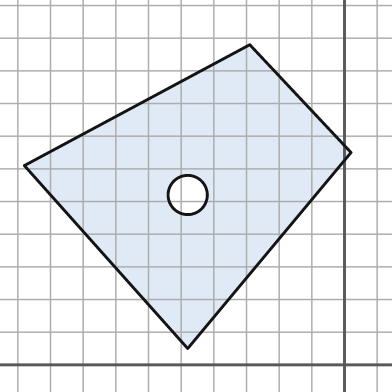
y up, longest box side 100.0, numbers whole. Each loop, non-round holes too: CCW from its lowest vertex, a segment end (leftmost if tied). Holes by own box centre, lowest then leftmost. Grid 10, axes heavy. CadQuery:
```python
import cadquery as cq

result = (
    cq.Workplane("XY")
    .moveTo(-48.0, 5.0)
    .lineTo(2.0, 65.0)
    .lineTo(-29.0, 98.0)
    .lineTo(-98.0, 61.0)
    .close()
    .moveTo(-48.0, 52.0)
    .circle(6.0)
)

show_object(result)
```